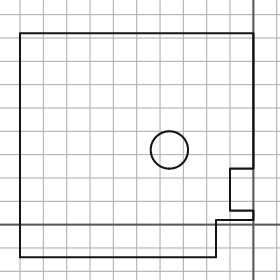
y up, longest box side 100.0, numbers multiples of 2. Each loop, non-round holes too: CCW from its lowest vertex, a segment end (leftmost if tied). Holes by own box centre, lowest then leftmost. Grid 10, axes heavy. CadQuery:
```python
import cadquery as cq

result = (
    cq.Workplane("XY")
    .moveTo(-100.0, -14.0)
    .lineTo(-16.0, -14.0)
    .lineTo(-16.0, 2.0)
    .lineTo(0.0, 2.0)
    .lineTo(0.0, 6.0)
    .lineTo(-10.0, 6.0)
    .lineTo(-10.0, 24.0)
    .lineTo(0.0, 24.0)
    .lineTo(0.0, 82.0)
    .lineTo(-100.0, 82.0)
    .close()
    .moveTo(-36.0, 32.0)
    .circle(8.0)
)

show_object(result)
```